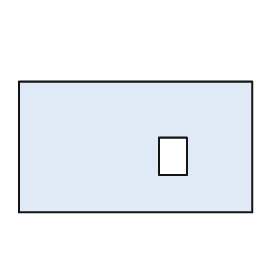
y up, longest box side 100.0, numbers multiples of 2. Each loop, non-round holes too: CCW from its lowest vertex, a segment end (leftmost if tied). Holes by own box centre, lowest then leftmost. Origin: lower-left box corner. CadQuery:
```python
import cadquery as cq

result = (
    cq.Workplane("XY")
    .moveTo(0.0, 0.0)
    .lineTo(100.0, 0.0)
    .lineTo(100.0, 56.0)
    .lineTo(0.0, 56.0)
    .close()
    .moveTo(60.0, 16.0)
    .lineTo(72.0, 16.0)
    .lineTo(72.0, 32.0)
    .lineTo(60.0, 32.0)
    .close()
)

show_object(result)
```